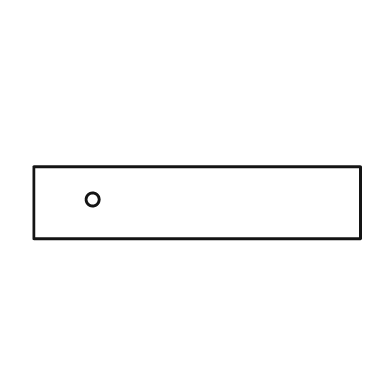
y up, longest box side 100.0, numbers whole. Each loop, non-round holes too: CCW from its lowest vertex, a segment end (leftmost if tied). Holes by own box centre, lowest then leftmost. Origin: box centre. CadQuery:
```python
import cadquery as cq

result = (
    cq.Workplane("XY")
    .moveTo(-50.0, -11.0)
    .lineTo(50.0, -11.0)
    .lineTo(50.0, 11.0)
    .lineTo(-50.0, 11.0)
    .close()
    .moveTo(-32.0, 1.0)
    .circle(2.0)
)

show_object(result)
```